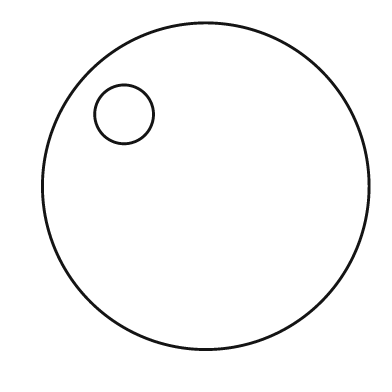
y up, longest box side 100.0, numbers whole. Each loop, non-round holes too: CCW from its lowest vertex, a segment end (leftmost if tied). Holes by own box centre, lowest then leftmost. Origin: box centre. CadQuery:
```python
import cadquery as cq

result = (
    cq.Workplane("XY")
    .moveTo(0.0, 0.0)
    .circle(50.0)
    .moveTo(-25.0, 22.0)
    .circle(9.0)
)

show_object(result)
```